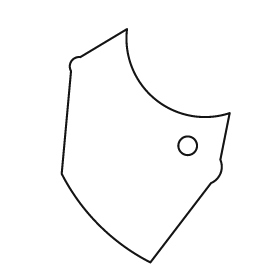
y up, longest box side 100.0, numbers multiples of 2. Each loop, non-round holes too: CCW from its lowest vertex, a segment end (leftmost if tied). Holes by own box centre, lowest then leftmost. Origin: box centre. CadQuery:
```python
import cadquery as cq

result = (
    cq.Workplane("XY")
    .moveTo(2.0, -50.0)
    .lineTo(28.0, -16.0)
    .threePointArc((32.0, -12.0), (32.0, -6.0))
    .lineTo(36.0, 14.0)
    .threePointArc((4.0, 20.0), (-8.0, 50.0))
    .lineTo(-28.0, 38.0)
    .threePointArc((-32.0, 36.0), (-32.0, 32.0))
    .lineTo(-36.0, -12.0)
    .threePointArc((-20.0, -34.0), (2.0, -50.0))
    .close()
    .moveTo(18.0, 0.0)
    .circle(4.0)
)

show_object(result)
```